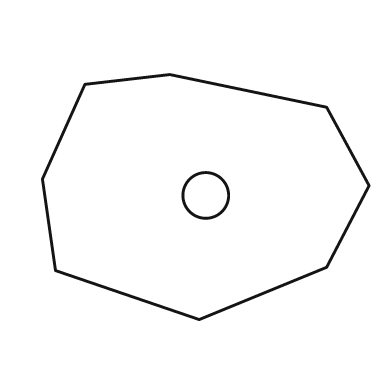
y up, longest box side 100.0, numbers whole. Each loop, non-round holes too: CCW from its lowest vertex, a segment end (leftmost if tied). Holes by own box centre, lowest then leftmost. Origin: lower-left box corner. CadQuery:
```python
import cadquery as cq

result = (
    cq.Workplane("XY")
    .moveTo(48.0, 0.0)
    .lineTo(87.0, 16.0)
    .lineTo(100.0, 41.0)
    .lineTo(87.0, 65.0)
    .lineTo(39.0, 75.0)
    .lineTo(13.0, 72.0)
    .lineTo(0.0, 43.0)
    .lineTo(4.0, 15.0)
    .close()
    .moveTo(50.0, 38.0)
    .circle(7.0)
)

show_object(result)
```